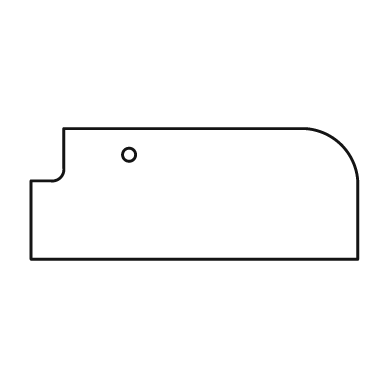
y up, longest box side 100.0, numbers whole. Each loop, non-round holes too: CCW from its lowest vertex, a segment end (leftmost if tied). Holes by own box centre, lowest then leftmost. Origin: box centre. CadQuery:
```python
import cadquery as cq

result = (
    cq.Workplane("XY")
    .moveTo(-50.0, -20.0)
    .lineTo(50.0, -20.0)
    .lineTo(50.0, 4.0)
    .threePointArc((45.0, 15.0), (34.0, 20.0))
    .lineTo(-40.0, 20.0)
    .lineTo(-40.0, 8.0)
    .threePointArc((-41.0, 5.0), (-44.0, 4.0))
    .lineTo(-50.0, 4.0)
    .close()
    .moveTo(-20.0, 12.0)
    .circle(2.0)
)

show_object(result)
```